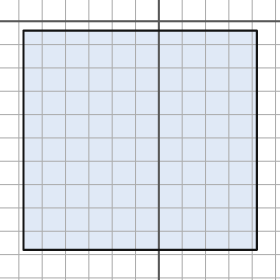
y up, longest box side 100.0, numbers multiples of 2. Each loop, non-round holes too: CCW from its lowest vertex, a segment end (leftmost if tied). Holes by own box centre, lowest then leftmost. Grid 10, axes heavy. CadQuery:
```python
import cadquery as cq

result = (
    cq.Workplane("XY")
    .moveTo(-58.0, -98.0)
    .lineTo(42.0, -98.0)
    .lineTo(42.0, -4.0)
    .lineTo(-58.0, -4.0)
    .close()
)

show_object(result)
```